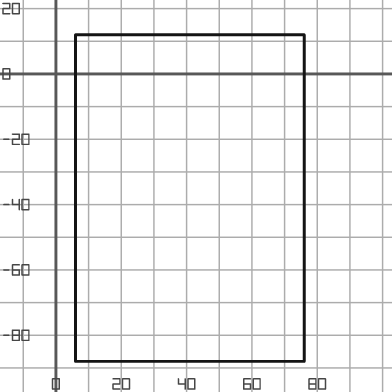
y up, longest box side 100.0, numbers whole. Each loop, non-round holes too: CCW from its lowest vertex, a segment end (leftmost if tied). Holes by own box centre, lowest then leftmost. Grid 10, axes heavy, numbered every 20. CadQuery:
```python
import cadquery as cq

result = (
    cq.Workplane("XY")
    .moveTo(6.0, -88.0)
    .lineTo(76.0, -88.0)
    .lineTo(76.0, 12.0)
    .lineTo(6.0, 12.0)
    .close()
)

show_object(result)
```